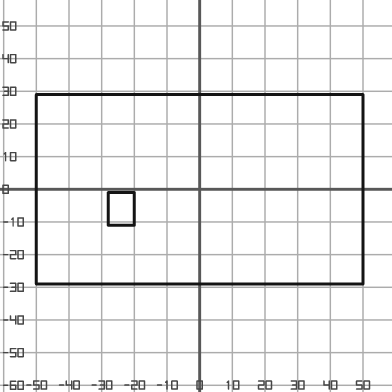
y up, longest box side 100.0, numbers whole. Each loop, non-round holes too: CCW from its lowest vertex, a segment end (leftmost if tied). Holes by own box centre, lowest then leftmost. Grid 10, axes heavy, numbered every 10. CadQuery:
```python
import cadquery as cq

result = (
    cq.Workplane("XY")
    .moveTo(-50.0, -29.0)
    .lineTo(50.0, -29.0)
    .lineTo(50.0, 29.0)
    .lineTo(-50.0, 29.0)
    .close()
    .moveTo(-28.0, -11.0)
    .lineTo(-20.0, -11.0)
    .lineTo(-20.0, -1.0)
    .lineTo(-28.0, -1.0)
    .close()
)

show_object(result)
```